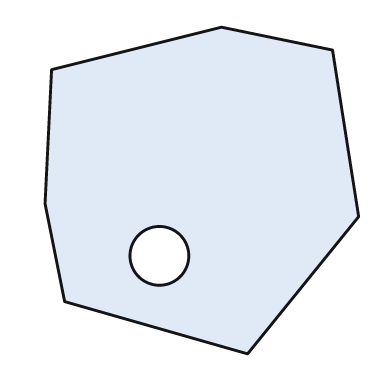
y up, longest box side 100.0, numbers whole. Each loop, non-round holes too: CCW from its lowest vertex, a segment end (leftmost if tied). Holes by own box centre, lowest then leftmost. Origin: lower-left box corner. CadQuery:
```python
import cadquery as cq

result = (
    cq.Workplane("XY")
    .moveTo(62.0, 0.0)
    .lineTo(96.0, 42.0)
    .lineTo(88.0, 93.0)
    .lineTo(54.0, 100.0)
    .lineTo(2.0, 87.0)
    .lineTo(0.0, 46.0)
    .lineTo(6.0, 16.0)
    .close()
    .moveTo(35.0, 30.0)
    .circle(9.0)
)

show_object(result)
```